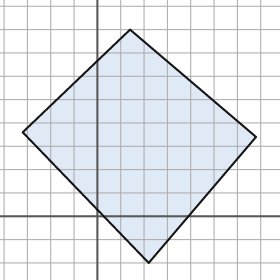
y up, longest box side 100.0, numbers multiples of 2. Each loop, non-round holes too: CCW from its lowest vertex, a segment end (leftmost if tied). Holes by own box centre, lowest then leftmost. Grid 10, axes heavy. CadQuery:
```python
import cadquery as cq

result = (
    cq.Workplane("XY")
    .moveTo(22.0, -20.0)
    .lineTo(68.0, 34.0)
    .lineTo(14.0, 80.0)
    .lineTo(-32.0, 36.0)
    .close()
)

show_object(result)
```